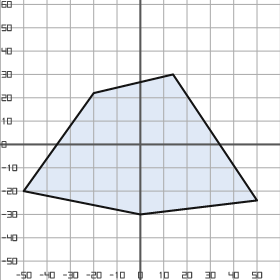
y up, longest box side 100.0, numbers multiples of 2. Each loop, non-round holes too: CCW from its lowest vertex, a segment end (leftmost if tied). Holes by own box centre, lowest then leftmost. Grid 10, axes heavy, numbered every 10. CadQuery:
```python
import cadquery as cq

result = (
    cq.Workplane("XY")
    .moveTo(0.0, -30.0)
    .lineTo(50.0, -24.0)
    .lineTo(14.0, 30.0)
    .lineTo(-20.0, 22.0)
    .lineTo(-50.0, -20.0)
    .close()
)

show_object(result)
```